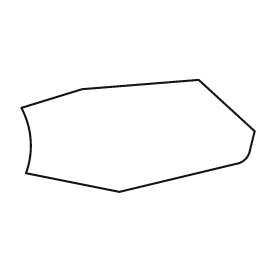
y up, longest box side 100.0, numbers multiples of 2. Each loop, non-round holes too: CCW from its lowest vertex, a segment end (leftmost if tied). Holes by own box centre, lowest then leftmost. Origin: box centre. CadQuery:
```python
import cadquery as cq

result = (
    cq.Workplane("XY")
    .moveTo(-8.0, -24.0)
    .lineTo(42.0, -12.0)
    .threePointArc((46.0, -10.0), (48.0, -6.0))
    .lineTo(50.0, 2.0)
    .lineTo(26.0, 24.0)
    .lineTo(-24.0, 20.0)
    .lineTo(-50.0, 12.0)
    .threePointArc((-46.0, -2.0), (-48.0, -16.0))
    .close()
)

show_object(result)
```